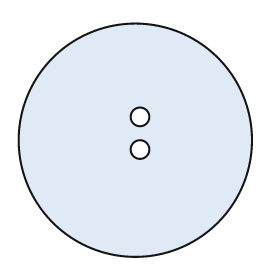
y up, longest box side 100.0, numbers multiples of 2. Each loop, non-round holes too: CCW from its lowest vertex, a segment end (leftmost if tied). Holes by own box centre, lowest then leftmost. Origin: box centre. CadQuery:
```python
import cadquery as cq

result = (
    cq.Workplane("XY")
    .moveTo(0.0, 0.0)
    .circle(50.0)
    .moveTo(2.0, -4.0)
    .circle(4.0)
    .moveTo(2.0, 10.0)
    .circle(4.0)
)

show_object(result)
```